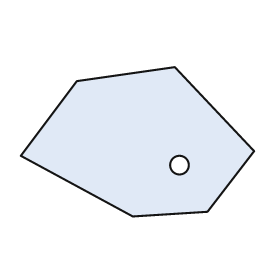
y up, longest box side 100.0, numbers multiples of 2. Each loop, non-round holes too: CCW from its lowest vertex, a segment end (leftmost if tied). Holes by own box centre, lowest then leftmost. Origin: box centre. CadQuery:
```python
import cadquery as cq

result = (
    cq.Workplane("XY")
    .moveTo(-2.0, -32.0)
    .lineTo(30.0, -30.0)
    .lineTo(50.0, -4.0)
    .lineTo(16.0, 32.0)
    .lineTo(-26.0, 26.0)
    .lineTo(-50.0, -6.0)
    .close()
    .moveTo(18.0, -10.0)
    .circle(4.0)
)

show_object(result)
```